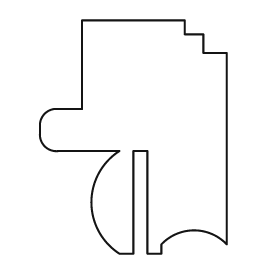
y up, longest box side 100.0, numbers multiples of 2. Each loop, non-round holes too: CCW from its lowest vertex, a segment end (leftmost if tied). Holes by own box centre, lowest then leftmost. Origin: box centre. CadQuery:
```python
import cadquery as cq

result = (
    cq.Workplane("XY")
    .moveTo(-6.0, -50.0)
    .lineTo(0.0, -50.0)
    .lineTo(0.0, -6.0)
    .lineTo(6.0, -6.0)
    .lineTo(6.0, -50.0)
    .lineTo(12.0, -50.0)
    .lineTo(12.0, -46.0)
    .threePointArc((26.0, -40.0), (40.0, -46.0))
    .lineTo(40.0, 36.0)
    .lineTo(30.0, 36.0)
    .lineTo(30.0, 44.0)
    .lineTo(22.0, 44.0)
    .lineTo(22.0, 50.0)
    .lineTo(-22.0, 50.0)
    .lineTo(-22.0, 12.0)
    .lineTo(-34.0, 12.0)
    .threePointArc((-38.0, 10.0), (-40.0, 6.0))
    .lineTo(-40.0, 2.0)
    .threePointArc((-38.0, -4.0), (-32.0, -6.0))
    .lineTo(-6.0, -6.0)
    .threePointArc((-18.0, -28.0), (-6.0, -50.0))
    .close()
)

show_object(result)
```